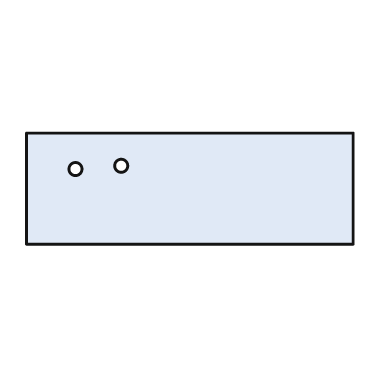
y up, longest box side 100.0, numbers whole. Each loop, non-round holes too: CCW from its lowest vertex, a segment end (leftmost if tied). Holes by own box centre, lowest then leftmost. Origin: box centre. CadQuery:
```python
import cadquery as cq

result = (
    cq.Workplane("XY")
    .moveTo(-50.0, -17.0)
    .lineTo(50.0, -17.0)
    .lineTo(50.0, 17.0)
    .lineTo(-50.0, 17.0)
    .close()
    .moveTo(-35.0, 6.0)
    .circle(2.0)
    .moveTo(-21.0, 7.0)
    .circle(2.0)
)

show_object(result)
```